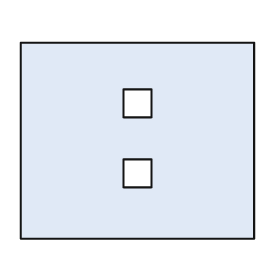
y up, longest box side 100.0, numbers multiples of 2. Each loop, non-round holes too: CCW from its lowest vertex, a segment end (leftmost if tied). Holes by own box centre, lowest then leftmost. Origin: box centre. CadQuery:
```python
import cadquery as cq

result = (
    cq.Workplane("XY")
    .moveTo(-50.0, -42.0)
    .lineTo(50.0, -42.0)
    .lineTo(50.0, 42.0)
    .lineTo(-50.0, 42.0)
    .close()
    .moveTo(-6.0, -20.0)
    .lineTo(6.0, -20.0)
    .lineTo(6.0, -8.0)
    .lineTo(-6.0, -8.0)
    .close()
    .moveTo(-6.0, 10.0)
    .lineTo(6.0, 10.0)
    .lineTo(6.0, 22.0)
    .lineTo(-6.0, 22.0)
    .close()
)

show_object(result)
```